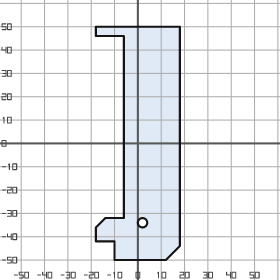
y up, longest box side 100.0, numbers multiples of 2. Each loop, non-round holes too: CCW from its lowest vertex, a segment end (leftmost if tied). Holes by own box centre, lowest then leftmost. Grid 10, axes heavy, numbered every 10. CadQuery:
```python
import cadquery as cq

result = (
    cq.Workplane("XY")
    .moveTo(-10.0, -50.0)
    .lineTo(12.0, -50.0)
    .lineTo(18.0, -44.0)
    .lineTo(18.0, 50.0)
    .lineTo(-18.0, 50.0)
    .lineTo(-18.0, 46.0)
    .lineTo(-6.0, 46.0)
    .lineTo(-6.0, -32.0)
    .lineTo(-14.0, -32.0)
    .lineTo(-18.0, -36.0)
    .lineTo(-18.0, -42.0)
    .lineTo(-10.0, -42.0)
    .close()
    .moveTo(2.0, -34.0)
    .circle(2.0)
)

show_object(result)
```